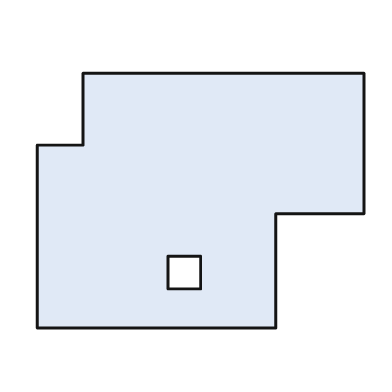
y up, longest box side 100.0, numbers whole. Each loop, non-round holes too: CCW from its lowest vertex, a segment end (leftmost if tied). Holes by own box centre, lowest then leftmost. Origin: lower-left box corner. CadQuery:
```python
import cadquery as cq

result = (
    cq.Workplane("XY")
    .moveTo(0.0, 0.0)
    .lineTo(73.0, 0.0)
    .lineTo(73.0, 35.0)
    .lineTo(100.0, 35.0)
    .lineTo(100.0, 78.0)
    .lineTo(14.0, 78.0)
    .lineTo(14.0, 56.0)
    .lineTo(0.0, 56.0)
    .close()
    .moveTo(40.0, 12.0)
    .lineTo(50.0, 12.0)
    .lineTo(50.0, 22.0)
    .lineTo(40.0, 22.0)
    .close()
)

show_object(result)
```